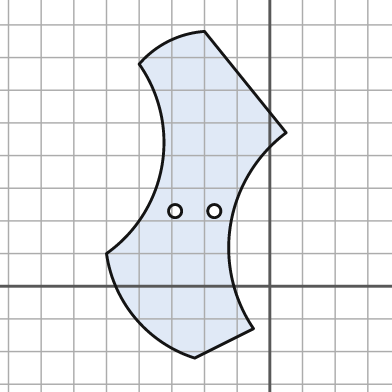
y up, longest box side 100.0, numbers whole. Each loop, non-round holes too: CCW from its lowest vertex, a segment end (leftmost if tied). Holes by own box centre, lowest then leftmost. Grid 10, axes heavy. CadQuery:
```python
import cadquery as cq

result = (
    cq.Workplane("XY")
    .moveTo(-23.0, -22.0)
    .lineTo(-5.0, -13.0)
    .threePointArc((-12.0, 19.0), (5.0, 47.0))
    .lineTo(-20.0, 78.0)
    .threePointArc((-31.0, 75.0), (-40.0, 68.0))
    .threePointArc((-33.0, 37.0), (-50.0, 10.0))
    .threePointArc((-41.0, -10.0), (-23.0, -22.0))
    .close()
    .moveTo(-29.0, 23.0)
    .circle(2.0)
    .moveTo(-17.0, 23.0)
    .circle(2.0)
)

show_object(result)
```